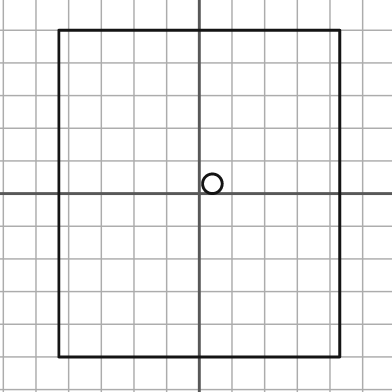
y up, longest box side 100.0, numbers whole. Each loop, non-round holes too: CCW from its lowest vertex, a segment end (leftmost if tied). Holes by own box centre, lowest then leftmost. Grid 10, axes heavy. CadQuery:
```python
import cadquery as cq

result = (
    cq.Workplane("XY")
    .moveTo(-43.0, -50.0)
    .lineTo(43.0, -50.0)
    .lineTo(43.0, 50.0)
    .lineTo(-43.0, 50.0)
    .close()
    .moveTo(4.0, 3.0)
    .circle(3.0)
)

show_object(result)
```